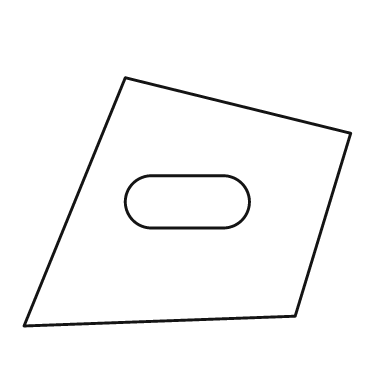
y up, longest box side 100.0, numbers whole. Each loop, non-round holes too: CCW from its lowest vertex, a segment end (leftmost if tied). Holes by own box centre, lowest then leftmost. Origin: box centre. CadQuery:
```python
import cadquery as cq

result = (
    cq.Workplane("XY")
    .moveTo(-50.0, -38.0)
    .lineTo(33.0, -35.0)
    .lineTo(50.0, 21.0)
    .lineTo(-19.0, 38.0)
    .close()
    .moveTo(-11.0, -8.0)
    .lineTo(11.0, -8.0)
    .threePointArc((19.0, 0.0), (11.0, 8.0))
    .lineTo(-11.0, 8.0)
    .threePointArc((-19.0, 0.0), (-11.0, -8.0))
    .close()
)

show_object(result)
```